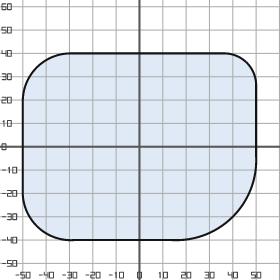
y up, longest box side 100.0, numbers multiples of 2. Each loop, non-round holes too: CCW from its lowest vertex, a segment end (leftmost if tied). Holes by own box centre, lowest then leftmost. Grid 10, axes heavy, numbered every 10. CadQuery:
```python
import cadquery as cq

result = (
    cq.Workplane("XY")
    .moveTo(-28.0, -40.0)
    .lineTo(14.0, -40.0)
    .threePointArc((40.0, -30.0), (50.0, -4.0))
    .lineTo(50.0, 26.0)
    .threePointArc((46.0, 36.0), (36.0, 40.0))
    .lineTo(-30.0, 40.0)
    .threePointArc((-44.0, 34.0), (-50.0, 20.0))
    .lineTo(-50.0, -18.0)
    .threePointArc((-44.0, -34.0), (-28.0, -40.0))
    .close()
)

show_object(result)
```